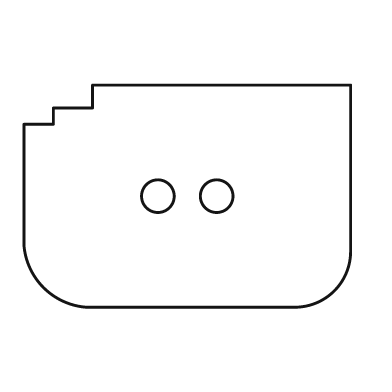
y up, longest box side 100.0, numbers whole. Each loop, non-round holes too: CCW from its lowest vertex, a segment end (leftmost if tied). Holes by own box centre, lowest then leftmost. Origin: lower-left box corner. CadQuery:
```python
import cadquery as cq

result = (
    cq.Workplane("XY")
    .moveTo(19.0, 0.0)
    .lineTo(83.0, 0.0)
    .threePointArc((95.0, 5.0), (100.0, 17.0))
    .lineTo(100.0, 68.0)
    .lineTo(21.0, 68.0)
    .lineTo(21.0, 61.0)
    .lineTo(9.0, 61.0)
    .lineTo(9.0, 56.0)
    .lineTo(0.0, 56.0)
    .lineTo(0.0, 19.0)
    .threePointArc((6.0, 6.0), (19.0, 0.0))
    .close()
    .moveTo(41.0, 34.0)
    .circle(5.0)
    .moveTo(59.0, 34.0)
    .circle(5.0)
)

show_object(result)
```